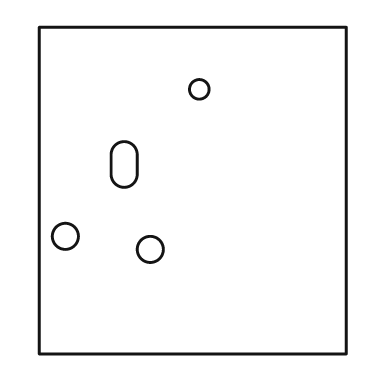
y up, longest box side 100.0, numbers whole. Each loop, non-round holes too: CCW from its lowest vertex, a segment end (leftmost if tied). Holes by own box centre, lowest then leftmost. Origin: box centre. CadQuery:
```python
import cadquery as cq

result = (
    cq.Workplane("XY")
    .moveTo(-47.0, -50.0)
    .lineTo(47.0, -50.0)
    .lineTo(47.0, 50.0)
    .lineTo(-47.0, 50.0)
    .close()
    .moveTo(-13.0, -18.0)
    .circle(4.0)
    .moveTo(-39.0, -14.0)
    .circle(4.0)
    .moveTo(-25.0, 5.0)
    .threePointArc((-21.0, 1.0), (-17.0, 5.0))
    .lineTo(-17.0, 11.0)
    .threePointArc((-21.0, 15.0), (-25.0, 11.0))
    .close()
    .moveTo(2.0, 31.0)
    .circle(3.0)
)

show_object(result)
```